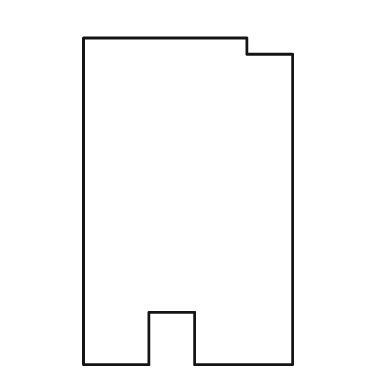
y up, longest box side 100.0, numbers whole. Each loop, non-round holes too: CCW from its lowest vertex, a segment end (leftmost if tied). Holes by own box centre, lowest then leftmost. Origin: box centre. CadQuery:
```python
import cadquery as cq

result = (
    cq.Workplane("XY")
    .moveTo(-32.0, -50.0)
    .lineTo(-12.0, -50.0)
    .lineTo(-12.0, -34.0)
    .lineTo(2.0, -34.0)
    .lineTo(2.0, -50.0)
    .lineTo(32.0, -50.0)
    .lineTo(32.0, 45.0)
    .lineTo(18.0, 45.0)
    .lineTo(18.0, 50.0)
    .lineTo(-32.0, 50.0)
    .close()
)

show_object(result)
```